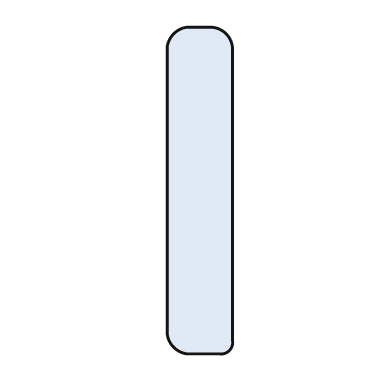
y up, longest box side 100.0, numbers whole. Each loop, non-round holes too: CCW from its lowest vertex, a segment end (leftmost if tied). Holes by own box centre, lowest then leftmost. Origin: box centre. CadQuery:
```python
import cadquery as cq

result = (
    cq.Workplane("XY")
    .moveTo(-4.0, -50.0)
    .lineTo(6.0, -50.0)
    .threePointArc((9.0, -49.0), (10.0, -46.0))
    .lineTo(10.0, 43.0)
    .threePointArc((8.0, 48.0), (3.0, 50.0))
    .lineTo(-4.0, 50.0)
    .threePointArc((-8.0, 48.0), (-10.0, 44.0))
    .lineTo(-10.0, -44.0)
    .threePointArc((-8.0, -48.0), (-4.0, -50.0))
    .close()
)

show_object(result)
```